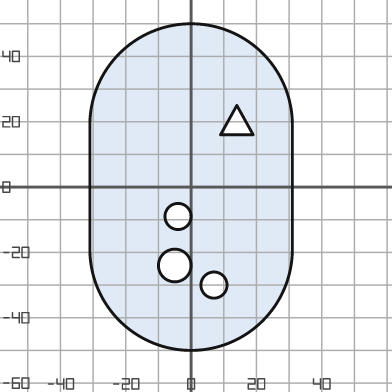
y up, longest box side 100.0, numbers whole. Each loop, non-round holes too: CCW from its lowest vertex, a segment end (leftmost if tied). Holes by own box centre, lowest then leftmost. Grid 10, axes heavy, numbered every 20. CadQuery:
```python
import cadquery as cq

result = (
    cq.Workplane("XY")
    .moveTo(-31.0, -19.0)
    .threePointArc((0.0, -50.0), (31.0, -19.0))
    .lineTo(31.0, 19.0)
    .threePointArc((0.0, 50.0), (-31.0, 19.0))
    .close()
    .moveTo(7.0, -30.0)
    .circle(4.0)
    .moveTo(-5.0, -24.0)
    .circle(5.0)
    .moveTo(-4.0, -9.0)
    .circle(4.0)
    .moveTo(9.0, 16.0)
    .lineTo(19.0, 16.0)
    .lineTo(14.0, 25.0)
    .close()
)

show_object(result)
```